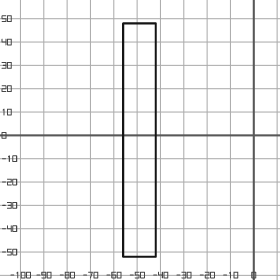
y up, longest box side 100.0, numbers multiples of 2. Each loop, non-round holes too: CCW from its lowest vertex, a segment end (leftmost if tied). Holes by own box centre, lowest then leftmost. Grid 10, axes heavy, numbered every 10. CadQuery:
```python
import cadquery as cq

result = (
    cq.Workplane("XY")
    .moveTo(-56.0, -52.0)
    .lineTo(-42.0, -52.0)
    .lineTo(-42.0, 48.0)
    .lineTo(-56.0, 48.0)
    .close()
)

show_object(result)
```